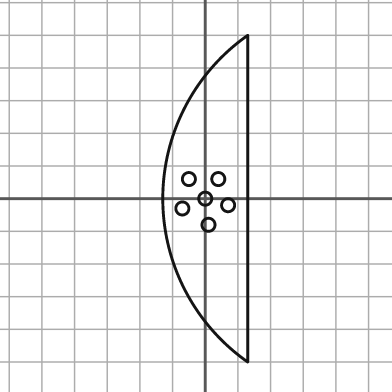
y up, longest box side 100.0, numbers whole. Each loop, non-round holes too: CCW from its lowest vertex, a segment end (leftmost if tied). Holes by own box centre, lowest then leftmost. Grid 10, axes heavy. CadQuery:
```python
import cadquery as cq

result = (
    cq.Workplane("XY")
    .moveTo(13.0, -50.0)
    .lineTo(13.0, 50.0)
    .threePointArc((-13.0, 0.0), (13.0, -50.0))
    .close()
    .moveTo(1.0, -8.0)
    .circle(2.0)
    .moveTo(-7.0, -3.0)
    .circle(2.0)
    .moveTo(7.0, -2.0)
    .circle(2.0)
    .moveTo(0.0, 0.0)
    .circle(2.0)
    .moveTo(-5.0, 6.0)
    .circle(2.0)
    .moveTo(4.0, 6.0)
    .circle(2.0)
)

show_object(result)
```